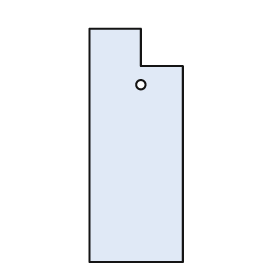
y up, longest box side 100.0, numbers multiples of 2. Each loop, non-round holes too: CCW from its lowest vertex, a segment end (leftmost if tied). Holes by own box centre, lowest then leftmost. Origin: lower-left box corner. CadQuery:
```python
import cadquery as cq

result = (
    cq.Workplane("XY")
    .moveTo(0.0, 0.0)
    .lineTo(40.0, 0.0)
    .lineTo(40.0, 84.0)
    .lineTo(22.0, 84.0)
    .lineTo(22.0, 100.0)
    .lineTo(0.0, 100.0)
    .close()
    .moveTo(22.0, 76.0)
    .circle(2.0)
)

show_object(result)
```